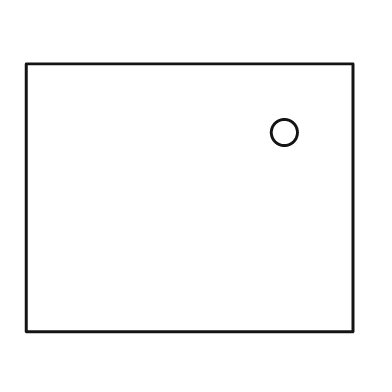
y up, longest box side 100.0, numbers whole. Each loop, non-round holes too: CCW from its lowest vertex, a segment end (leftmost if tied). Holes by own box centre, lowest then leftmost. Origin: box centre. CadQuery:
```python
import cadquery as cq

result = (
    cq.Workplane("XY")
    .moveTo(-50.0, -41.0)
    .lineTo(50.0, -41.0)
    .lineTo(50.0, 41.0)
    .lineTo(-50.0, 41.0)
    .close()
    .moveTo(29.0, 20.0)
    .circle(4.0)
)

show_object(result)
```